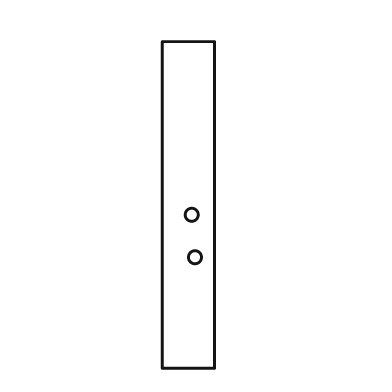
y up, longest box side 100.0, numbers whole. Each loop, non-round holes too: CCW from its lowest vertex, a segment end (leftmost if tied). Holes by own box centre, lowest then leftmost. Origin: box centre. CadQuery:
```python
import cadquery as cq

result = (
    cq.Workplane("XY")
    .moveTo(-8.0, -50.0)
    .lineTo(8.0, -50.0)
    .lineTo(8.0, 50.0)
    .lineTo(-8.0, 50.0)
    .close()
    .moveTo(2.0, -16.0)
    .circle(2.0)
    .moveTo(1.0, -3.0)
    .circle(2.0)
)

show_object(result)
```